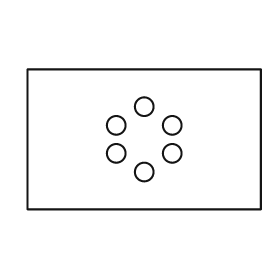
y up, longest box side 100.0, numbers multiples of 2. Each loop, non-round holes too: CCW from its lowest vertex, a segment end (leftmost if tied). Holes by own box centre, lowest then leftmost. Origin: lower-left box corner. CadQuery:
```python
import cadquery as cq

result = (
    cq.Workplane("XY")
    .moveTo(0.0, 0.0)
    .lineTo(100.0, 0.0)
    .lineTo(100.0, 60.0)
    .lineTo(0.0, 60.0)
    .close()
    .moveTo(50.0, 16.0)
    .circle(4.0)
    .moveTo(38.0, 24.0)
    .circle(4.0)
    .moveTo(62.0, 24.0)
    .circle(4.0)
    .moveTo(38.0, 36.0)
    .circle(4.0)
    .moveTo(62.0, 36.0)
    .circle(4.0)
    .moveTo(50.0, 44.0)
    .circle(4.0)
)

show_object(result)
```